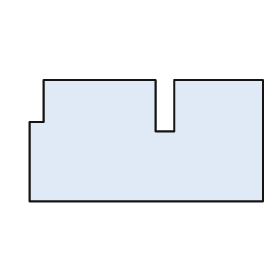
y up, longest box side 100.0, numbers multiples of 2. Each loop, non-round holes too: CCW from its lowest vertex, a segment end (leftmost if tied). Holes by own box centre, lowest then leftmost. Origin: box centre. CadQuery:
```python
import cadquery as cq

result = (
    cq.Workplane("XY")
    .moveTo(-50.0, -26.0)
    .lineTo(50.0, -26.0)
    .lineTo(50.0, 26.0)
    .lineTo(12.0, 26.0)
    .lineTo(12.0, 4.0)
    .lineTo(4.0, 4.0)
    .lineTo(4.0, 26.0)
    .lineTo(-44.0, 26.0)
    .lineTo(-44.0, 8.0)
    .lineTo(-50.0, 8.0)
    .close()
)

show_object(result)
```